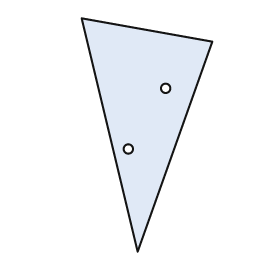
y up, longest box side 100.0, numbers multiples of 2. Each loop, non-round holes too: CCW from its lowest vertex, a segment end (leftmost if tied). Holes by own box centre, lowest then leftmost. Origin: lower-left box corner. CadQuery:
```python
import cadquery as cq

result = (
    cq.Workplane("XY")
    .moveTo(24.0, 0.0)
    .lineTo(56.0, 90.0)
    .lineTo(0.0, 100.0)
    .close()
    .moveTo(20.0, 44.0)
    .circle(2.0)
    .moveTo(36.0, 70.0)
    .circle(2.0)
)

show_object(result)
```